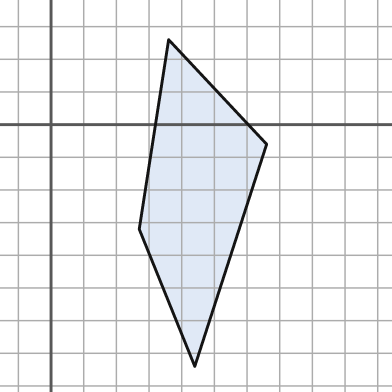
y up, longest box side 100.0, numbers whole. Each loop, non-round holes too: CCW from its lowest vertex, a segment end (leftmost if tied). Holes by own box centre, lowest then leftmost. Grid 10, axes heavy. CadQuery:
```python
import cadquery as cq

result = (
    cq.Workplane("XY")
    .moveTo(44.0, -74.0)
    .lineTo(66.0, -6.0)
    .lineTo(36.0, 26.0)
    .lineTo(27.0, -32.0)
    .close()
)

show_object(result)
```